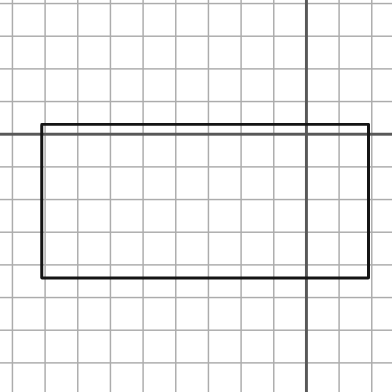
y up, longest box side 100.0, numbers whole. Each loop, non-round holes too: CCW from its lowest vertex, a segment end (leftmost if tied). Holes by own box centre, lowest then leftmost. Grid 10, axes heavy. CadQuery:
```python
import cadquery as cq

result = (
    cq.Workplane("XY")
    .moveTo(-81.0, -44.0)
    .lineTo(19.0, -44.0)
    .lineTo(19.0, 3.0)
    .lineTo(-81.0, 3.0)
    .close()
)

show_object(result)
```